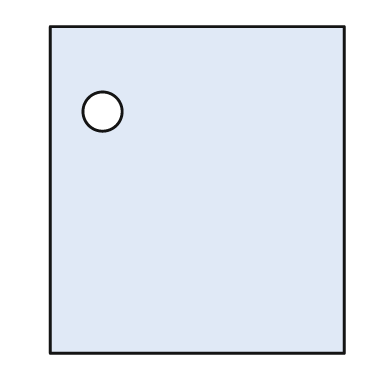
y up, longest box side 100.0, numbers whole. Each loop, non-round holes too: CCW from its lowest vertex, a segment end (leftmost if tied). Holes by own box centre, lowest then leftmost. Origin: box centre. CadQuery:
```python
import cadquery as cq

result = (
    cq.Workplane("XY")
    .moveTo(-45.0, -50.0)
    .lineTo(45.0, -50.0)
    .lineTo(45.0, 50.0)
    .lineTo(-45.0, 50.0)
    .close()
    .moveTo(-29.0, 24.0)
    .circle(6.0)
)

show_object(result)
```